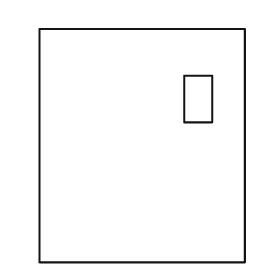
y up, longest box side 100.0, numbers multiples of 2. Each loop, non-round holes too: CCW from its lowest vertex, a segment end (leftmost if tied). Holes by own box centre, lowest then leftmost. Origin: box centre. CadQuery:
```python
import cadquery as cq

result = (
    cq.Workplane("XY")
    .moveTo(-44.0, -50.0)
    .lineTo(44.0, -50.0)
    .lineTo(44.0, 50.0)
    .lineTo(-44.0, 50.0)
    .close()
    .moveTo(18.0, 10.0)
    .lineTo(30.0, 10.0)
    .lineTo(30.0, 30.0)
    .lineTo(18.0, 30.0)
    .close()
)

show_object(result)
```